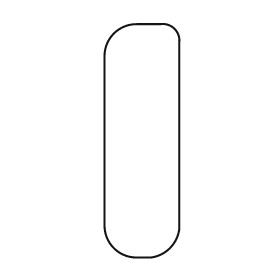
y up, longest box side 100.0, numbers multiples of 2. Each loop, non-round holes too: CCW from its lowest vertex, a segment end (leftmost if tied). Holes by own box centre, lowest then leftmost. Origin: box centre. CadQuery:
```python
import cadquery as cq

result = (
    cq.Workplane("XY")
    .moveTo(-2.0, -50.0)
    .lineTo(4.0, -50.0)
    .threePointArc((12.0, -46.0), (16.0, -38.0))
    .lineTo(16.0, 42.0)
    .threePointArc((14.0, 48.0), (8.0, 50.0))
    .lineTo(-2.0, 50.0)
    .threePointArc((-12.0, 46.0), (-16.0, 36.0))
    .lineTo(-16.0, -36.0)
    .threePointArc((-12.0, -46.0), (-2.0, -50.0))
    .close()
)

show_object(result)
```